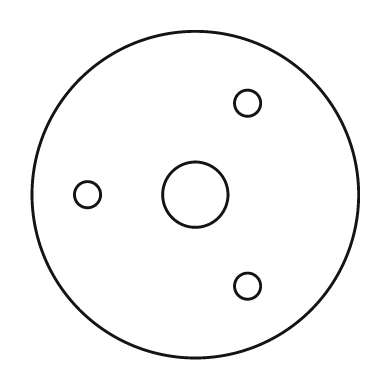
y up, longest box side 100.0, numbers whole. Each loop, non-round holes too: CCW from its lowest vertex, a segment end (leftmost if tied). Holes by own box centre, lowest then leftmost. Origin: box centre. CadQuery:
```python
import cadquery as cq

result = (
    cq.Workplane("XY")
    .moveTo(0.0, 0.0)
    .circle(50.0)
    .moveTo(16.0, -28.0)
    .circle(4.0)
    .moveTo(-33.0, 0.0)
    .circle(4.0)
    .moveTo(0.0, 0.0)
    .circle(10.0)
    .moveTo(16.0, 28.0)
    .circle(4.0)
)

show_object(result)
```